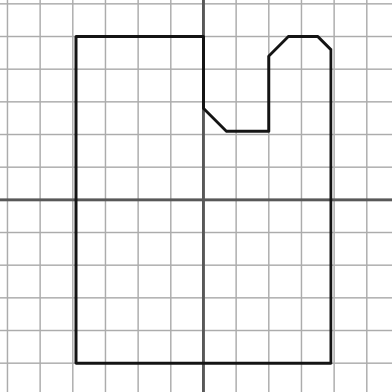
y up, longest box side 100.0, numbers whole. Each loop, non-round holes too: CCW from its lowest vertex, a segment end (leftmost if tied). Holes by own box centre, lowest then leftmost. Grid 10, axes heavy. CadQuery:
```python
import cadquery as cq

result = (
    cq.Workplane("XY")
    .moveTo(-39.0, -50.0)
    .lineTo(39.0, -50.0)
    .lineTo(39.0, 46.0)
    .lineTo(35.0, 50.0)
    .lineTo(26.0, 50.0)
    .lineTo(20.0, 44.0)
    .lineTo(20.0, 21.0)
    .lineTo(7.0, 21.0)
    .lineTo(0.0, 28.0)
    .lineTo(0.0, 50.0)
    .lineTo(-39.0, 50.0)
    .close()
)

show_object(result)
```